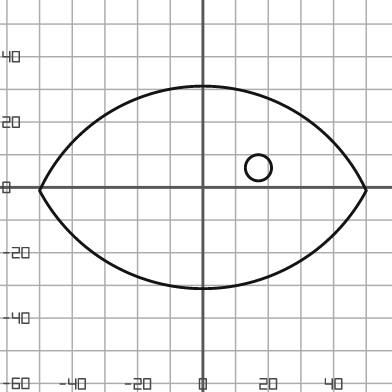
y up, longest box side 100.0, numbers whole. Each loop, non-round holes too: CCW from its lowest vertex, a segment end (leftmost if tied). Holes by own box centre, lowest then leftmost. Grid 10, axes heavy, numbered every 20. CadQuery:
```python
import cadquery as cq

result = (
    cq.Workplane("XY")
    .moveTo(-50.0, -1.0)
    .threePointArc((0.0, -31.0), (50.0, -1.0))
    .threePointArc((0.0, 31.0), (-50.0, -1.0))
    .close()
    .moveTo(17.0, 6.0)
    .circle(4.0)
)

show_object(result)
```